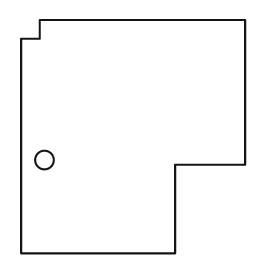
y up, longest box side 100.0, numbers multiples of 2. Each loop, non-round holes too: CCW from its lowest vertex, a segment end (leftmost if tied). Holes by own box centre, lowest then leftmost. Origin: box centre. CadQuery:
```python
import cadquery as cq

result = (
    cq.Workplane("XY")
    .moveTo(-48.0, -50.0)
    .lineTo(18.0, -50.0)
    .lineTo(18.0, -12.0)
    .lineTo(48.0, -12.0)
    .lineTo(48.0, 50.0)
    .lineTo(-40.0, 50.0)
    .lineTo(-40.0, 42.0)
    .lineTo(-48.0, 42.0)
    .close()
    .moveTo(-38.0, -10.0)
    .circle(4.0)
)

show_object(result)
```